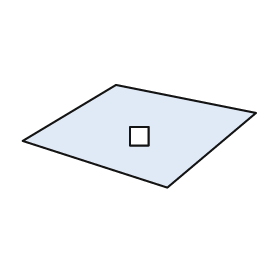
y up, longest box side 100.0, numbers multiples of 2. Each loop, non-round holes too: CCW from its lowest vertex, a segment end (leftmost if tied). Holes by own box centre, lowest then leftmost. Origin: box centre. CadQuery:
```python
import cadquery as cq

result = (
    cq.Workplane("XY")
    .moveTo(12.0, -22.0)
    .lineTo(50.0, 10.0)
    .lineTo(-10.0, 22.0)
    .lineTo(-50.0, -2.0)
    .close()
    .moveTo(-4.0, -4.0)
    .lineTo(4.0, -4.0)
    .lineTo(4.0, 4.0)
    .lineTo(-4.0, 4.0)
    .close()
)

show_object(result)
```